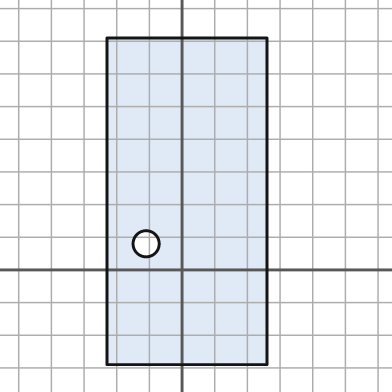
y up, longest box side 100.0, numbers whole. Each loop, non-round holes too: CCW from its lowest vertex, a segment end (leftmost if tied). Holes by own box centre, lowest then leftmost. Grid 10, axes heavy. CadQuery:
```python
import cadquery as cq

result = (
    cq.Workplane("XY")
    .moveTo(-23.0, -29.0)
    .lineTo(26.0, -29.0)
    .lineTo(26.0, 71.0)
    .lineTo(-23.0, 71.0)
    .close()
    .moveTo(-11.0, 8.0)
    .circle(4.0)
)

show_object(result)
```